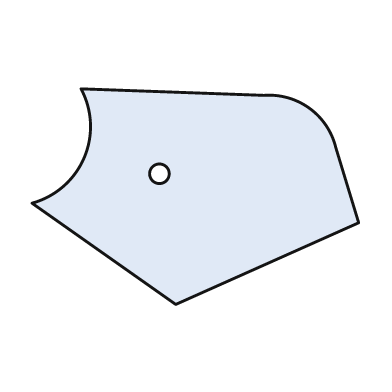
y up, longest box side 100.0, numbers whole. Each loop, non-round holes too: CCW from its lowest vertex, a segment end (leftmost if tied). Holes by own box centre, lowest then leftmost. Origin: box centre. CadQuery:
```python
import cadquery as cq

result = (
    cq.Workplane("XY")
    .moveTo(-6.0, -33.0)
    .lineTo(50.0, -8.0)
    .lineTo(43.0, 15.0)
    .threePointArc((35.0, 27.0), (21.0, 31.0))
    .lineTo(-35.0, 33.0)
    .threePointArc((-34.0, 12.0), (-50.0, -2.0))
    .close()
    .moveTo(-11.0, 7.0)
    .circle(3.0)
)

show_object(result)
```